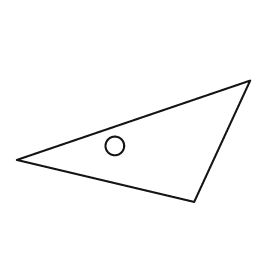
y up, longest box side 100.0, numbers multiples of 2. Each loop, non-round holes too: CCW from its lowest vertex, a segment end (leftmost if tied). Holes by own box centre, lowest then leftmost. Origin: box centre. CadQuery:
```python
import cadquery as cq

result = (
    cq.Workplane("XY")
    .moveTo(26.0, -26.0)
    .lineTo(50.0, 26.0)
    .lineTo(-50.0, -8.0)
    .close()
    .moveTo(-8.0, -2.0)
    .circle(4.0)
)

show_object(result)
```